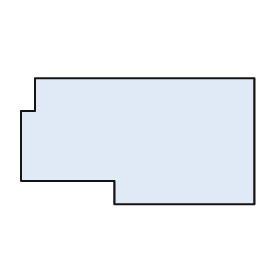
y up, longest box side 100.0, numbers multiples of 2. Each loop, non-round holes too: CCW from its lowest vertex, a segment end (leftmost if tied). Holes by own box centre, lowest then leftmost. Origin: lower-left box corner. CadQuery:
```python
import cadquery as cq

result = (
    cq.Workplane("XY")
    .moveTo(40.0, 0.0)
    .lineTo(100.0, 0.0)
    .lineTo(100.0, 54.0)
    .lineTo(6.0, 54.0)
    .lineTo(6.0, 40.0)
    .lineTo(0.0, 40.0)
    .lineTo(0.0, 10.0)
    .lineTo(40.0, 10.0)
    .close()
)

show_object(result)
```